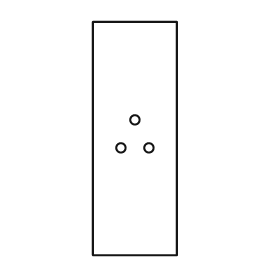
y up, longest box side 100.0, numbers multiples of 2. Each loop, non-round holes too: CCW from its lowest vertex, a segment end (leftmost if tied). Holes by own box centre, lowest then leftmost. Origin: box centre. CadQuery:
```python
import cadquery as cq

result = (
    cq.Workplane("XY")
    .moveTo(-18.0, -50.0)
    .lineTo(18.0, -50.0)
    .lineTo(18.0, 50.0)
    .lineTo(-18.0, 50.0)
    .close()
    .moveTo(-6.0, -4.0)
    .circle(2.0)
    .moveTo(6.0, -4.0)
    .circle(2.0)
    .moveTo(0.0, 8.0)
    .circle(2.0)
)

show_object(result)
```